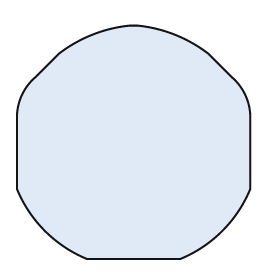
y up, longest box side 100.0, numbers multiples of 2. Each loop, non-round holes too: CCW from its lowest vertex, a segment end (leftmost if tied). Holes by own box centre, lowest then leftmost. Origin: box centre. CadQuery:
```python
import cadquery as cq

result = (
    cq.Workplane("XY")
    .moveTo(-20.0, -50.0)
    .lineTo(20.0, -50.0)
    .threePointArc((38.0, -38.0), (50.0, -20.0))
    .lineTo(50.0, 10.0)
    .threePointArc((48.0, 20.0), (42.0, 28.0))
    .lineTo(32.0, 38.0)
    .threePointArc((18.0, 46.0), (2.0, 50.0))
    .lineTo(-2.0, 50.0)
    .threePointArc((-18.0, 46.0), (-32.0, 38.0))
    .lineTo(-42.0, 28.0)
    .threePointArc((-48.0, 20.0), (-50.0, 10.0))
    .lineTo(-50.0, -20.0)
    .threePointArc((-38.0, -38.0), (-20.0, -50.0))
    .close()
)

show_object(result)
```